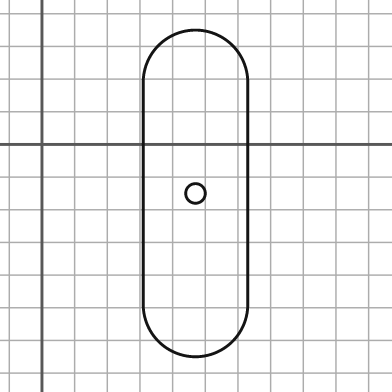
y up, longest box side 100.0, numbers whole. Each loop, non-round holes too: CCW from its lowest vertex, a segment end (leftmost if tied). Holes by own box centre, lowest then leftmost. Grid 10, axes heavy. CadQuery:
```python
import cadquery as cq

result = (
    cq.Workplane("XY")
    .moveTo(31.0, -49.0)
    .threePointArc((47.0, -65.0), (63.0, -49.0))
    .lineTo(63.0, 19.0)
    .threePointArc((47.0, 35.0), (31.0, 19.0))
    .close()
    .moveTo(47.0, -15.0)
    .circle(3.0)
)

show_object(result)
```